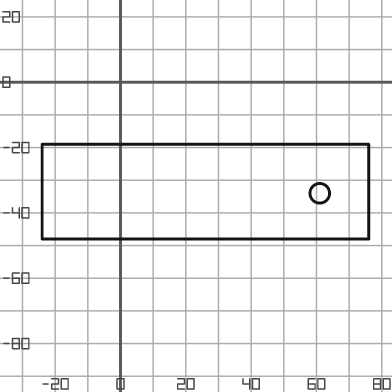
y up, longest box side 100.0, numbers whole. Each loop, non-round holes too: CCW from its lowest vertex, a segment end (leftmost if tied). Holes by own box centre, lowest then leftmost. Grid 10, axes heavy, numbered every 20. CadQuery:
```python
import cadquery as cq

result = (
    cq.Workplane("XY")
    .moveTo(-24.0, -48.0)
    .lineTo(76.0, -48.0)
    .lineTo(76.0, -19.0)
    .lineTo(-24.0, -19.0)
    .close()
    .moveTo(61.0, -34.0)
    .circle(3.0)
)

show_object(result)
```